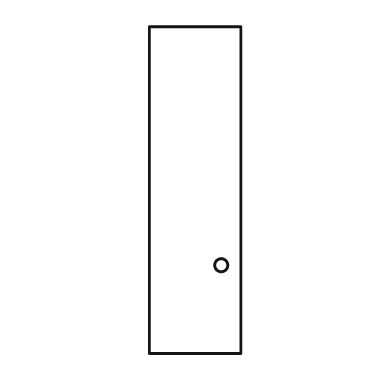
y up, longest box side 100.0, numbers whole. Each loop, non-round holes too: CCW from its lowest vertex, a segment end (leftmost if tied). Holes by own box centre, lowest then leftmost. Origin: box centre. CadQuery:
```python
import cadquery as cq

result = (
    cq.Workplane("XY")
    .moveTo(-14.0, -50.0)
    .lineTo(14.0, -50.0)
    .lineTo(14.0, 50.0)
    .lineTo(-14.0, 50.0)
    .close()
    .moveTo(8.0, -23.0)
    .circle(2.0)
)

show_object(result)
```